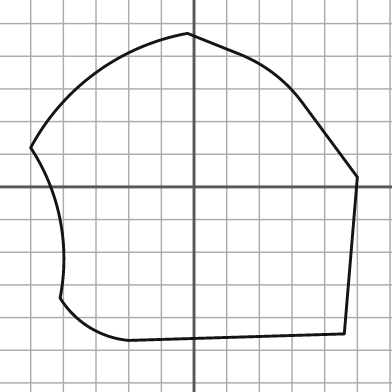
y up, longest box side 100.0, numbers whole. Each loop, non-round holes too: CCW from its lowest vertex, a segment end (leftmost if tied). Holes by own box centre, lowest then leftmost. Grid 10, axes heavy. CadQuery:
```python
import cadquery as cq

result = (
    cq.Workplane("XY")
    .moveTo(-20.0, -47.0)
    .lineTo(46.0, -45.0)
    .lineTo(50.0, 3.0)
    .lineTo(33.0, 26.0)
    .threePointArc((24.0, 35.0), (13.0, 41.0))
    .lineTo(-2.0, 47.0)
    .threePointArc((-30.0, 35.0), (-50.0, 12.0))
    .threePointArc((-41.0, -10.0), (-41.0, -34.0))
    .threePointArc((-32.0, -43.0), (-20.0, -47.0))
    .close()
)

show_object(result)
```